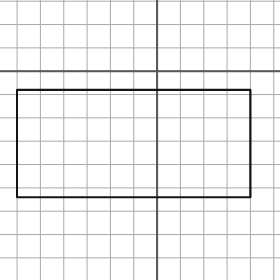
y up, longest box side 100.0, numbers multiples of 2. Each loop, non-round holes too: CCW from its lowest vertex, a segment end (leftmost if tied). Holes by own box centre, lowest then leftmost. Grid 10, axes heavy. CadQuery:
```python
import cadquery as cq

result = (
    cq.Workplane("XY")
    .moveTo(-60.0, -54.0)
    .lineTo(40.0, -54.0)
    .lineTo(40.0, -8.0)
    .lineTo(-60.0, -8.0)
    .close()
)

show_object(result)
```